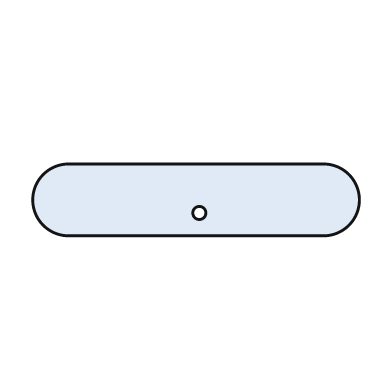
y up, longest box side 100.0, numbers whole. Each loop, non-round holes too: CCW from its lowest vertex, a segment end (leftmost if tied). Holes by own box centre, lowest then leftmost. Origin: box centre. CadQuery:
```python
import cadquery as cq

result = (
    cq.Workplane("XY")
    .moveTo(-39.0, -11.0)
    .lineTo(39.0, -11.0)
    .threePointArc((50.0, 0.0), (39.0, 11.0))
    .lineTo(-39.0, 11.0)
    .threePointArc((-50.0, 0.0), (-39.0, -11.0))
    .close()
    .moveTo(1.0, -4.0)
    .circle(2.0)
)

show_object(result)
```